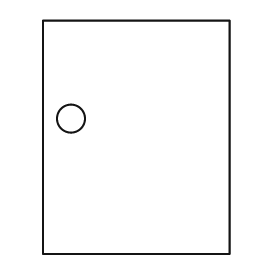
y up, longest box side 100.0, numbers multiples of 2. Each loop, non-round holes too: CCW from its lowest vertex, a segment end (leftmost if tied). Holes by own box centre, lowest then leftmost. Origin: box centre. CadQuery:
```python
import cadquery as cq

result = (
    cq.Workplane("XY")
    .moveTo(-40.0, -50.0)
    .lineTo(40.0, -50.0)
    .lineTo(40.0, 50.0)
    .lineTo(-40.0, 50.0)
    .close()
    .moveTo(-28.0, 8.0)
    .circle(6.0)
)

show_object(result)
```